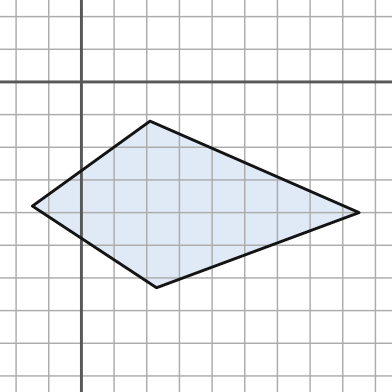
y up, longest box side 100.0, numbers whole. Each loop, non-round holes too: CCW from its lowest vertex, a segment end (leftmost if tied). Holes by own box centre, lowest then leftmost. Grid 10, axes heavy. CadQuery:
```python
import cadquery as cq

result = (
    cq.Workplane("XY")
    .moveTo(23.0, -63.0)
    .lineTo(85.0, -40.0)
    .lineTo(21.0, -12.0)
    .lineTo(-15.0, -38.0)
    .close()
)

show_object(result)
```